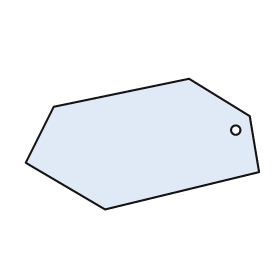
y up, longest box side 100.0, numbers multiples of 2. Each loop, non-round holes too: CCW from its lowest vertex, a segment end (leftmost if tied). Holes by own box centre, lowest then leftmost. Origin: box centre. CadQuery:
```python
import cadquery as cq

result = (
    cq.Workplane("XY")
    .moveTo(-16.0, -28.0)
    .lineTo(50.0, -12.0)
    .lineTo(46.0, 12.0)
    .lineTo(20.0, 28.0)
    .lineTo(-38.0, 16.0)
    .lineTo(-50.0, -8.0)
    .close()
    .moveTo(40.0, 6.0)
    .circle(2.0)
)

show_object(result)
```